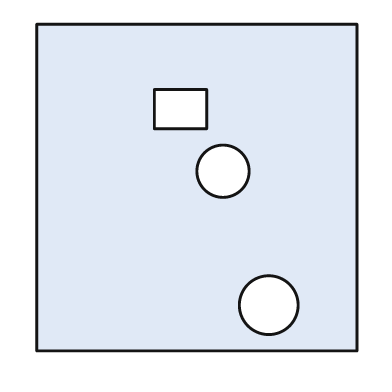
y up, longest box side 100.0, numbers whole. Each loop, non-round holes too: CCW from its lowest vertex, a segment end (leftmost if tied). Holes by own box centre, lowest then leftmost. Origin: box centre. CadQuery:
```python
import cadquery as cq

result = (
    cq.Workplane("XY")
    .moveTo(-49.0, -50.0)
    .lineTo(49.0, -50.0)
    .lineTo(49.0, 50.0)
    .lineTo(-49.0, 50.0)
    .close()
    .moveTo(22.0, -36.0)
    .circle(9.0)
    .moveTo(8.0, 5.0)
    .circle(8.0)
    .moveTo(-13.0, 18.0)
    .lineTo(3.0, 18.0)
    .lineTo(3.0, 30.0)
    .lineTo(-13.0, 30.0)
    .close()
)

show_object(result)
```